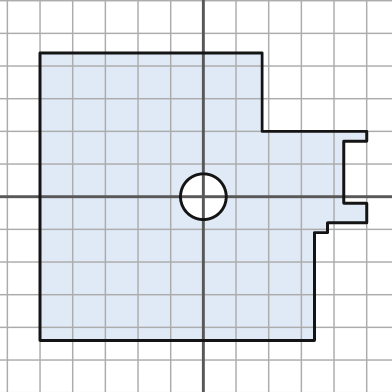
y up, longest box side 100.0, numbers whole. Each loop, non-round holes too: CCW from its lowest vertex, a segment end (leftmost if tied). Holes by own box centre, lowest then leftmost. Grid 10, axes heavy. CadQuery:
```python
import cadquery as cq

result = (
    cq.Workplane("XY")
    .moveTo(-50.0, -44.0)
    .lineTo(34.0, -44.0)
    .lineTo(34.0, -11.0)
    .lineTo(38.0, -11.0)
    .lineTo(38.0, -8.0)
    .lineTo(50.0, -8.0)
    .lineTo(50.0, -2.0)
    .lineTo(43.0, -2.0)
    .lineTo(43.0, 17.0)
    .lineTo(50.0, 17.0)
    .lineTo(50.0, 20.0)
    .lineTo(18.0, 20.0)
    .lineTo(18.0, 44.0)
    .lineTo(-50.0, 44.0)
    .close()
    .moveTo(0.0, 0.0)
    .circle(7.0)
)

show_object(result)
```